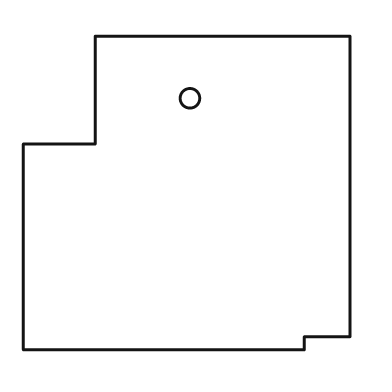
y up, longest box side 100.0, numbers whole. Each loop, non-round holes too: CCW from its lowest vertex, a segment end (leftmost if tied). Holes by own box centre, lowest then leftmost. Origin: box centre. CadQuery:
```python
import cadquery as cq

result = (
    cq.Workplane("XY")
    .moveTo(-50.0, -48.0)
    .lineTo(36.0, -48.0)
    .lineTo(36.0, -44.0)
    .lineTo(50.0, -44.0)
    .lineTo(50.0, 48.0)
    .lineTo(-28.0, 48.0)
    .lineTo(-28.0, 15.0)
    .lineTo(-50.0, 15.0)
    .close()
    .moveTo(1.0, 29.0)
    .circle(3.0)
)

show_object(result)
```